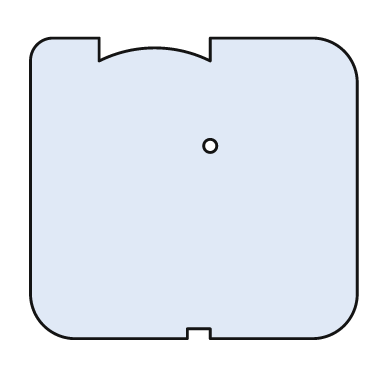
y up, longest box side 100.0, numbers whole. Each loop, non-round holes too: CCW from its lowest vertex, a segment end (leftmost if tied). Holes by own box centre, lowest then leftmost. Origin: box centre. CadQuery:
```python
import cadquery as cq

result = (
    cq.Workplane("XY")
    .moveTo(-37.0, -46.0)
    .lineTo(-2.0, -46.0)
    .lineTo(-2.0, -43.0)
    .lineTo(5.0, -43.0)
    .lineTo(5.0, -46.0)
    .lineTo(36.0, -46.0)
    .threePointArc((46.0, -42.0), (50.0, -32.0))
    .lineTo(50.0, 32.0)
    .threePointArc((46.0, 42.0), (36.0, 46.0))
    .lineTo(5.0, 46.0)
    .lineTo(5.0, 39.0)
    .threePointArc((-12.0, 43.0), (-29.0, 39.0))
    .lineTo(-29.0, 46.0)
    .lineTo(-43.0, 46.0)
    .threePointArc((-48.0, 44.0), (-50.0, 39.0))
    .lineTo(-50.0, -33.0)
    .threePointArc((-46.0, -42.0), (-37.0, -46.0))
    .close()
    .moveTo(5.0, 13.0)
    .circle(2.0)
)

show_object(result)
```